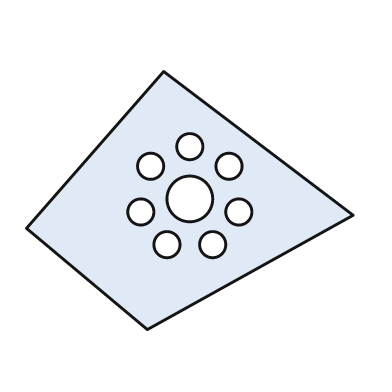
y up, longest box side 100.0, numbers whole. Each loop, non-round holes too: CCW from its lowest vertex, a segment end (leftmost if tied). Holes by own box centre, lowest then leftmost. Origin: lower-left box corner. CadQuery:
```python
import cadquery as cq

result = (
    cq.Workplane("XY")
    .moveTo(37.0, 0.0)
    .lineTo(100.0, 35.0)
    .lineTo(42.0, 79.0)
    .lineTo(0.0, 31.0)
    .close()
    .moveTo(43.0, 26.0)
    .circle(4.0)
    .moveTo(57.0, 26.0)
    .circle(4.0)
    .moveTo(35.0, 36.0)
    .circle(4.0)
    .moveTo(65.0, 36.0)
    .circle(4.0)
    .moveTo(50.0, 40.0)
    .circle(7.0)
    .moveTo(38.0, 50.0)
    .circle(4.0)
    .moveTo(62.0, 50.0)
    .circle(4.0)
    .moveTo(50.0, 56.0)
    .circle(4.0)
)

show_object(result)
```